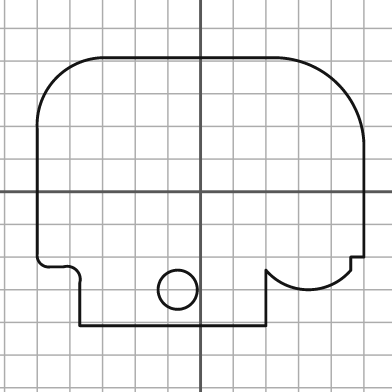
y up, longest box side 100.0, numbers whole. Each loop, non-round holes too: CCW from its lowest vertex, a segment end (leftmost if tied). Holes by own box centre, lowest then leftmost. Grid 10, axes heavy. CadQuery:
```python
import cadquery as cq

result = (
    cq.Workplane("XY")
    .moveTo(-37.0, -41.0)
    .lineTo(20.0, -41.0)
    .lineTo(20.0, -24.0)
    .threePointArc((33.0, -30.0), (46.0, -24.0))
    .lineTo(46.0, -20.0)
    .lineTo(50.0, -20.0)
    .lineTo(50.0, 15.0)
    .threePointArc((42.0, 33.0), (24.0, 41.0))
    .lineTo(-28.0, 41.0)
    .threePointArc((-44.0, 35.0), (-50.0, 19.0))
    .lineTo(-50.0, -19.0)
    .threePointArc((-49.0, -22.0), (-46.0, -23.0))
    .lineTo(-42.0, -23.0)
    .threePointArc((-38.0, -24.0), (-37.0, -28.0))
    .close()
    .moveTo(-7.0, -30.0)
    .circle(6.0)
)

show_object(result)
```